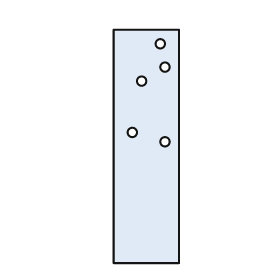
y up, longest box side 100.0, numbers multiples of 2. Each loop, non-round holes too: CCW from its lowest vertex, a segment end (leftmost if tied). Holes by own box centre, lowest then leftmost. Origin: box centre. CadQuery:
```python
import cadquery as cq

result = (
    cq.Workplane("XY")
    .moveTo(-14.0, -50.0)
    .lineTo(14.0, -50.0)
    .lineTo(14.0, 50.0)
    .lineTo(-14.0, 50.0)
    .close()
    .moveTo(8.0, 2.0)
    .circle(2.0)
    .moveTo(-6.0, 6.0)
    .circle(2.0)
    .moveTo(-2.0, 28.0)
    .circle(2.0)
    .moveTo(8.0, 34.0)
    .circle(2.0)
    .moveTo(6.0, 44.0)
    .circle(2.0)
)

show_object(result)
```